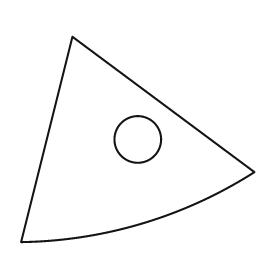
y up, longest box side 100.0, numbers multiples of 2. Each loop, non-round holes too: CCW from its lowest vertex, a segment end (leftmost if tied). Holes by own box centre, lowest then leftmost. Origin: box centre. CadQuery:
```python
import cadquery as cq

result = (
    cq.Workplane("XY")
    .moveTo(-50.0, -44.0)
    .threePointArc((2.0, -36.0), (50.0, -14.0))
    .lineTo(-28.0, 44.0)
    .close()
    .moveTo(0.0, 0.0)
    .circle(10.0)
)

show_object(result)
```